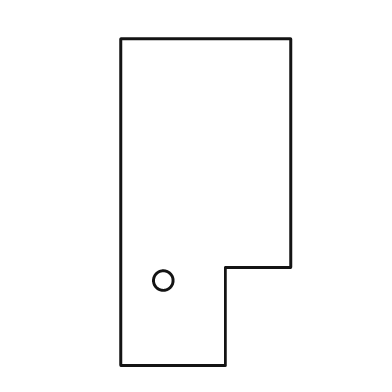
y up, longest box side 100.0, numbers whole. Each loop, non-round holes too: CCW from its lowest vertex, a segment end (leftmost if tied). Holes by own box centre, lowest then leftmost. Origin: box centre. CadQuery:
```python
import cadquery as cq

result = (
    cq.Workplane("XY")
    .moveTo(-26.0, -50.0)
    .lineTo(6.0, -50.0)
    .lineTo(6.0, -20.0)
    .lineTo(26.0, -20.0)
    .lineTo(26.0, 50.0)
    .lineTo(-26.0, 50.0)
    .close()
    .moveTo(-13.0, -24.0)
    .circle(3.0)
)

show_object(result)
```